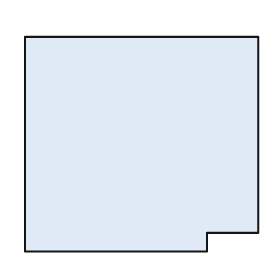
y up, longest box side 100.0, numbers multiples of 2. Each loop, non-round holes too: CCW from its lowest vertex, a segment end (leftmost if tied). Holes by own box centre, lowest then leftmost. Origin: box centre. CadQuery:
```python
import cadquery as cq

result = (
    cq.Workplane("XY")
    .moveTo(-50.0, -46.0)
    .lineTo(28.0, -46.0)
    .lineTo(28.0, -38.0)
    .lineTo(50.0, -38.0)
    .lineTo(50.0, 46.0)
    .lineTo(-50.0, 46.0)
    .close()
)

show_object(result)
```